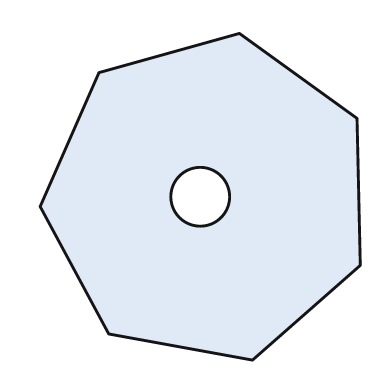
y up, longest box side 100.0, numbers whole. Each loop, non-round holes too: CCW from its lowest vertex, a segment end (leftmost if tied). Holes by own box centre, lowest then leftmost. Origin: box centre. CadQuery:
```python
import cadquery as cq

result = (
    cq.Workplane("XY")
    .moveTo(16.0, -50.0)
    .lineTo(49.0, -21.0)
    .lineTo(48.0, 24.0)
    .lineTo(12.0, 50.0)
    .lineTo(-31.0, 38.0)
    .lineTo(-49.0, -3.0)
    .lineTo(-28.0, -42.0)
    .close()
    .moveTo(0.0, 0.0)
    .circle(9.0)
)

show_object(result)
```